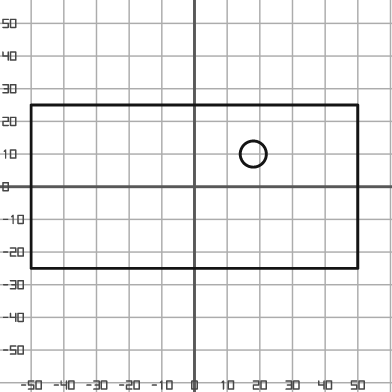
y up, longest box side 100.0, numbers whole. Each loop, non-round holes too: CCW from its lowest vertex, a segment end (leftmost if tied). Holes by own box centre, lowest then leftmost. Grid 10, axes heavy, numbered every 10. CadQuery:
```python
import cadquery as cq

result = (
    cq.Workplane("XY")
    .moveTo(-50.0, -25.0)
    .lineTo(50.0, -25.0)
    .lineTo(50.0, 25.0)
    .lineTo(-50.0, 25.0)
    .close()
    .moveTo(18.0, 10.0)
    .circle(4.0)
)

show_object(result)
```